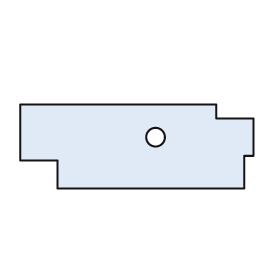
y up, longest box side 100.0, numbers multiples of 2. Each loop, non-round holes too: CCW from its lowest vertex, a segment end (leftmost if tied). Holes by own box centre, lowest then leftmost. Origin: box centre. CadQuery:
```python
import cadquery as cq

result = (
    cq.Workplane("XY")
    .moveTo(-34.0, -18.0)
    .lineTo(46.0, -18.0)
    .lineTo(46.0, -4.0)
    .lineTo(50.0, -4.0)
    .lineTo(50.0, 12.0)
    .lineTo(34.0, 12.0)
    .lineTo(34.0, 18.0)
    .lineTo(-50.0, 18.0)
    .lineTo(-50.0, -6.0)
    .lineTo(-34.0, -6.0)
    .close()
    .moveTo(8.0, 4.0)
    .circle(4.0)
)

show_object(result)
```